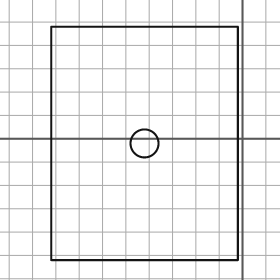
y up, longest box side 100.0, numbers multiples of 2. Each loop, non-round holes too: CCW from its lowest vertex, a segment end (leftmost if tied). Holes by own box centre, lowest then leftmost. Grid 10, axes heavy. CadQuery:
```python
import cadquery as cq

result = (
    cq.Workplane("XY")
    .moveTo(-82.0, -52.0)
    .lineTo(-2.0, -52.0)
    .lineTo(-2.0, 48.0)
    .lineTo(-82.0, 48.0)
    .close()
    .moveTo(-42.0, -2.0)
    .circle(6.0)
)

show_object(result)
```